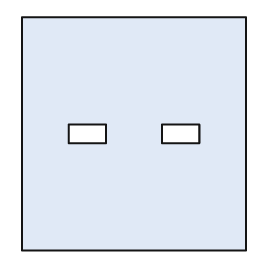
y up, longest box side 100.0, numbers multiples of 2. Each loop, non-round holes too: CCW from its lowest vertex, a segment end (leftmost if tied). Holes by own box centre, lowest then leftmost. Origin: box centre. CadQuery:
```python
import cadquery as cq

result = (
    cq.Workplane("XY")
    .moveTo(-48.0, -50.0)
    .lineTo(48.0, -50.0)
    .lineTo(48.0, 50.0)
    .lineTo(-48.0, 50.0)
    .close()
    .moveTo(-28.0, -4.0)
    .lineTo(-12.0, -4.0)
    .lineTo(-12.0, 4.0)
    .lineTo(-28.0, 4.0)
    .close()
    .moveTo(12.0, -4.0)
    .lineTo(28.0, -4.0)
    .lineTo(28.0, 4.0)
    .lineTo(12.0, 4.0)
    .close()
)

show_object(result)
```